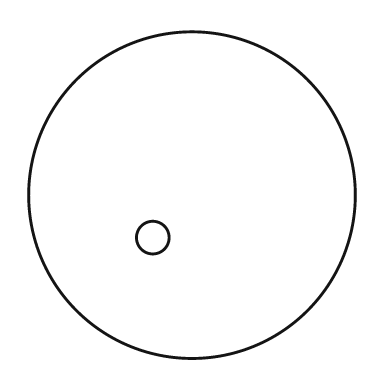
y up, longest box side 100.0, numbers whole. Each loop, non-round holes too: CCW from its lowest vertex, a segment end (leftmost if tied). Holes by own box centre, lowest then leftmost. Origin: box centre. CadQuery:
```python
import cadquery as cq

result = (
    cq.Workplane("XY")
    .moveTo(0.0, 0.0)
    .circle(50.0)
    .moveTo(-12.0, -13.0)
    .circle(5.0)
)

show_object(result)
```